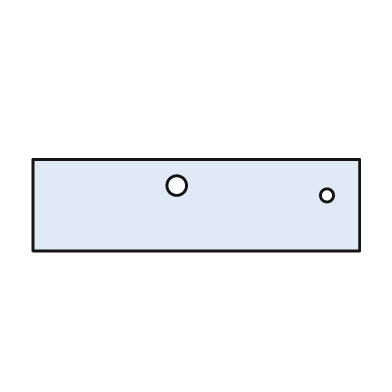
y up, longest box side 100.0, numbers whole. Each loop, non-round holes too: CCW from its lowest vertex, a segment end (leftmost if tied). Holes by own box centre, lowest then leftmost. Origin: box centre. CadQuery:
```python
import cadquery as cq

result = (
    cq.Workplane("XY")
    .moveTo(-50.0, -14.0)
    .lineTo(50.0, -14.0)
    .lineTo(50.0, 14.0)
    .lineTo(-50.0, 14.0)
    .close()
    .moveTo(40.0, 3.0)
    .circle(2.0)
    .moveTo(-6.0, 6.0)
    .circle(3.0)
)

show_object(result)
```